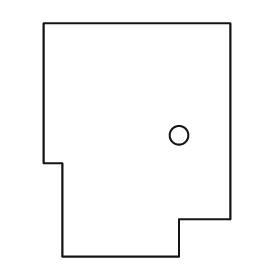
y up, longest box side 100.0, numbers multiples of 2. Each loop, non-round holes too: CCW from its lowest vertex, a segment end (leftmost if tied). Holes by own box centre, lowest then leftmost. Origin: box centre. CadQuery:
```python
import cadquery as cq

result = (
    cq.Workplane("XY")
    .moveTo(-32.0, -50.0)
    .lineTo(18.0, -50.0)
    .lineTo(18.0, -34.0)
    .lineTo(40.0, -34.0)
    .lineTo(40.0, 50.0)
    .lineTo(-40.0, 50.0)
    .lineTo(-40.0, -10.0)
    .lineTo(-32.0, -10.0)
    .close()
    .moveTo(18.0, 2.0)
    .circle(4.0)
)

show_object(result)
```